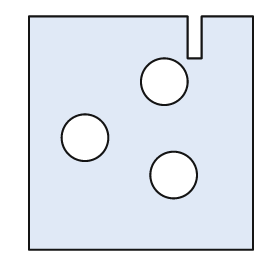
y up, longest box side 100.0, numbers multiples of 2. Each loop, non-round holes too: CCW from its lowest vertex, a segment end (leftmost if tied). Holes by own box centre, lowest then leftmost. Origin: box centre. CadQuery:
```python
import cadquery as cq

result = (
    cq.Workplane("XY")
    .moveTo(-48.0, -50.0)
    .lineTo(48.0, -50.0)
    .lineTo(48.0, 50.0)
    .lineTo(26.0, 50.0)
    .lineTo(26.0, 32.0)
    .lineTo(20.0, 32.0)
    .lineTo(20.0, 50.0)
    .lineTo(-48.0, 50.0)
    .close()
    .moveTo(14.0, -18.0)
    .circle(10.0)
    .moveTo(-24.0, -2.0)
    .circle(10.0)
    .moveTo(10.0, 22.0)
    .circle(10.0)
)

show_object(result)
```